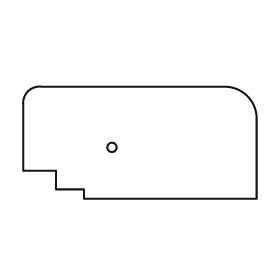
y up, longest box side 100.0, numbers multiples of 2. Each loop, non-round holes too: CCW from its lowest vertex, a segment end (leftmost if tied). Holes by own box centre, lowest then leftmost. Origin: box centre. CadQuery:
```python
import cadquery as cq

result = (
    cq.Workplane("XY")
    .moveTo(-24.0, -24.0)
    .lineTo(50.0, -24.0)
    .lineTo(50.0, 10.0)
    .threePointArc((46.0, 20.0), (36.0, 24.0))
    .lineTo(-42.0, 24.0)
    .threePointArc((-48.0, 22.0), (-50.0, 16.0))
    .lineTo(-50.0, -12.0)
    .lineTo(-36.0, -12.0)
    .lineTo(-36.0, -20.0)
    .lineTo(-24.0, -20.0)
    .close()
    .moveTo(-12.0, -2.0)
    .circle(2.0)
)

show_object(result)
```